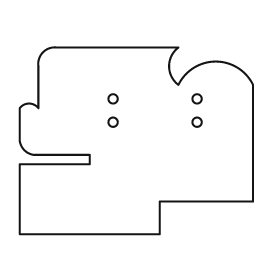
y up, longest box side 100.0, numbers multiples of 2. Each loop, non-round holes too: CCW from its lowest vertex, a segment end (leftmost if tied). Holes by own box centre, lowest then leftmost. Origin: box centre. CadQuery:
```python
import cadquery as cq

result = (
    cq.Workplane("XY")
    .moveTo(-50.0, -40.0)
    .lineTo(10.0, -40.0)
    .lineTo(10.0, -26.0)
    .lineTo(50.0, -26.0)
    .lineTo(50.0, 24.0)
    .threePointArc((34.0, 34.0), (18.0, 24.0))
    .threePointArc((14.0, 32.0), (18.0, 40.0))
    .lineTo(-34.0, 40.0)
    .threePointArc((-40.0, 38.0), (-42.0, 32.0))
    .lineTo(-42.0, 14.0)
    .threePointArc((-46.0, 16.0), (-50.0, 14.0))
    .lineTo(-50.0, 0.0)
    .threePointArc((-48.0, -4.0), (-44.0, -6.0))
    .lineTo(-20.0, -6.0)
    .lineTo(-20.0, -10.0)
    .lineTo(-50.0, -10.0)
    .close()
    .moveTo(-10.0, 8.0)
    .circle(2.0)
    .moveTo(26.0, 8.0)
    .circle(2.0)
    .moveTo(-10.0, 18.0)
    .circle(2.0)
    .moveTo(26.0, 18.0)
    .circle(2.0)
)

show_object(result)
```